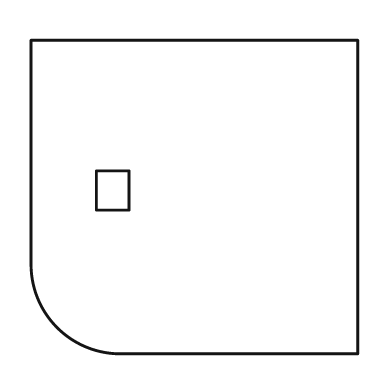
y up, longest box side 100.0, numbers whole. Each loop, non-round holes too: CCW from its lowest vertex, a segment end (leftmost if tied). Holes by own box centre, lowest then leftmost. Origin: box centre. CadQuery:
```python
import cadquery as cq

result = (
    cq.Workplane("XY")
    .moveTo(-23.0, -48.0)
    .lineTo(50.0, -48.0)
    .lineTo(50.0, 48.0)
    .lineTo(-50.0, 48.0)
    .lineTo(-50.0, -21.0)
    .threePointArc((-42.0, -40.0), (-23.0, -48.0))
    .close()
    .moveTo(-30.0, -4.0)
    .lineTo(-20.0, -4.0)
    .lineTo(-20.0, 8.0)
    .lineTo(-30.0, 8.0)
    .close()
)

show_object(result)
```